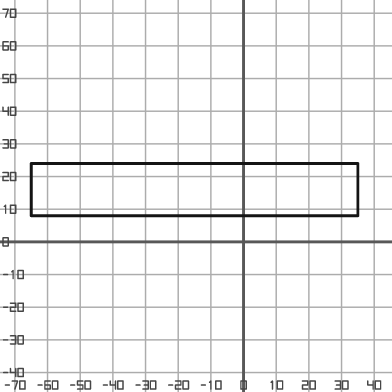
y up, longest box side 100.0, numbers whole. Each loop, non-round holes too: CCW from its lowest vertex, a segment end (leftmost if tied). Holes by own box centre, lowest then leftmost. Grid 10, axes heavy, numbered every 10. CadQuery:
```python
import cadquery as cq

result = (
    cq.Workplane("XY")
    .moveTo(-65.0, 8.0)
    .lineTo(35.0, 8.0)
    .lineTo(35.0, 24.0)
    .lineTo(-65.0, 24.0)
    .close()
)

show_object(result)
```